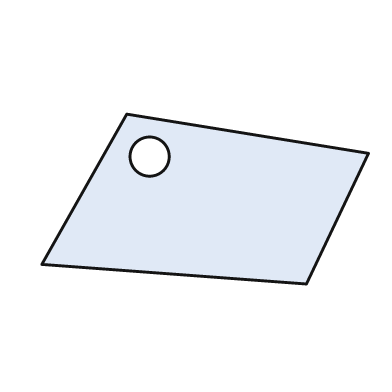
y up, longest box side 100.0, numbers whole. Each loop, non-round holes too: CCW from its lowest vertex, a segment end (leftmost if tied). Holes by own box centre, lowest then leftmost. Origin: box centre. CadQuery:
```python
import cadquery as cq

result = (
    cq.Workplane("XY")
    .moveTo(31.0, -26.0)
    .lineTo(50.0, 14.0)
    .lineTo(-24.0, 26.0)
    .lineTo(-50.0, -20.0)
    .close()
    .moveTo(-17.0, 13.0)
    .circle(6.0)
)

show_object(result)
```